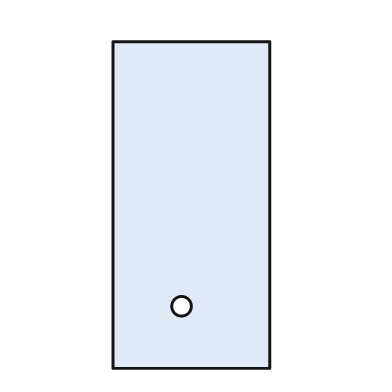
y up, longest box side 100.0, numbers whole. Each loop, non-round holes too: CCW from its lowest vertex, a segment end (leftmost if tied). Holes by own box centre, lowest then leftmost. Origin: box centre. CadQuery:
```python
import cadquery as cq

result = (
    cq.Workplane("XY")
    .moveTo(-24.0, -50.0)
    .lineTo(24.0, -50.0)
    .lineTo(24.0, 50.0)
    .lineTo(-24.0, 50.0)
    .close()
    .moveTo(-3.0, -31.0)
    .circle(3.0)
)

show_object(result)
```